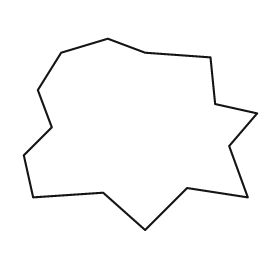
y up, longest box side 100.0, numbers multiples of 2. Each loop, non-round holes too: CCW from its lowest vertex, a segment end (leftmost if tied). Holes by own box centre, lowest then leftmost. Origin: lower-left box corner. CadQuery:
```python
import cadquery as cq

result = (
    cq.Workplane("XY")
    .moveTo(52.0, 0.0)
    .lineTo(70.0, 18.0)
    .lineTo(96.0, 14.0)
    .lineTo(88.0, 36.0)
    .lineTo(100.0, 50.0)
    .lineTo(82.0, 54.0)
    .lineTo(80.0, 74.0)
    .lineTo(52.0, 76.0)
    .lineTo(36.0, 82.0)
    .lineTo(16.0, 76.0)
    .lineTo(6.0, 60.0)
    .lineTo(12.0, 44.0)
    .lineTo(0.0, 32.0)
    .lineTo(4.0, 14.0)
    .lineTo(34.0, 16.0)
    .close()
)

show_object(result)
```